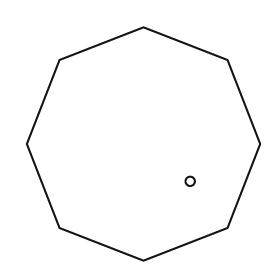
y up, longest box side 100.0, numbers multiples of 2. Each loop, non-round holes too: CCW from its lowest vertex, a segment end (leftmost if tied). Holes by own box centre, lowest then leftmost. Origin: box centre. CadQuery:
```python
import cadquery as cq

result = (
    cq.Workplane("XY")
    .moveTo(0.0, -50.0)
    .lineTo(36.0, -36.0)
    .lineTo(50.0, 0.0)
    .lineTo(36.0, 36.0)
    .lineTo(0.0, 50.0)
    .lineTo(-36.0, 36.0)
    .lineTo(-50.0, 0.0)
    .lineTo(-36.0, -36.0)
    .close()
    .moveTo(20.0, -16.0)
    .circle(2.0)
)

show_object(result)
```